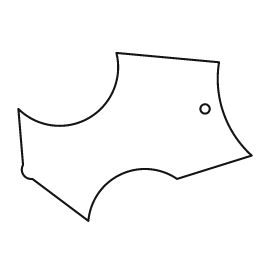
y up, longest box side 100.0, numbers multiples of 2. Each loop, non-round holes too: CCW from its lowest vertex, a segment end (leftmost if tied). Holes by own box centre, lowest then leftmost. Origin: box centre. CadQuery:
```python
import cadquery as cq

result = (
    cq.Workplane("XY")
    .moveTo(-20.0, -36.0)
    .threePointArc((-6.0, -16.0), (18.0, -18.0))
    .lineTo(50.0, -8.0)
    .threePointArc((38.0, 10.0), (36.0, 32.0))
    .lineTo(-8.0, 36.0)
    .threePointArc((-20.0, 8.0), (-50.0, 12.0))
    .lineTo(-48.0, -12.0)
    .threePointArc((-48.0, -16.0), (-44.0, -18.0))
    .close()
    .moveTo(30.0, 12.0)
    .circle(2.0)
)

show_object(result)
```